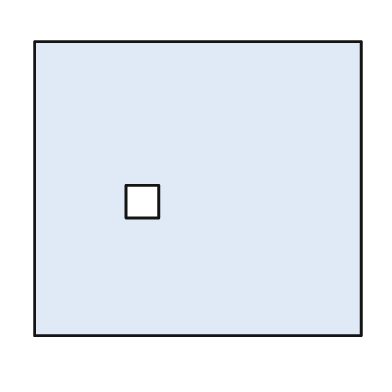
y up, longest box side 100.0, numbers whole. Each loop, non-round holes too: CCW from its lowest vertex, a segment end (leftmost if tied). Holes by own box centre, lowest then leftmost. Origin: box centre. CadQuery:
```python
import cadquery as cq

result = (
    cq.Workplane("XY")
    .moveTo(-50.0, -45.0)
    .lineTo(50.0, -45.0)
    .lineTo(50.0, 45.0)
    .lineTo(-50.0, 45.0)
    .close()
    .moveTo(-22.0, -9.0)
    .lineTo(-12.0, -9.0)
    .lineTo(-12.0, 1.0)
    .lineTo(-22.0, 1.0)
    .close()
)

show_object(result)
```